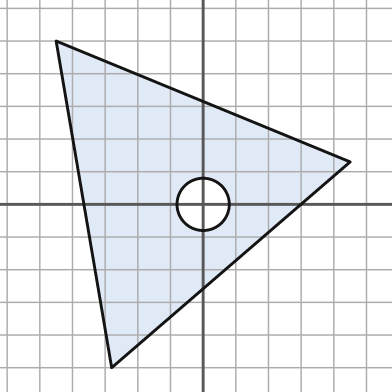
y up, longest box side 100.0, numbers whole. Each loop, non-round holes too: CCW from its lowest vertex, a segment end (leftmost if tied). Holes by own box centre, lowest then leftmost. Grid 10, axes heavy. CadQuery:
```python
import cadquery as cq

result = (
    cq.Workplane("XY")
    .moveTo(-28.0, -50.0)
    .lineTo(45.0, 13.0)
    .lineTo(-45.0, 50.0)
    .close()
    .moveTo(0.0, 0.0)
    .circle(8.0)
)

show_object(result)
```